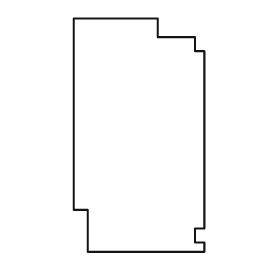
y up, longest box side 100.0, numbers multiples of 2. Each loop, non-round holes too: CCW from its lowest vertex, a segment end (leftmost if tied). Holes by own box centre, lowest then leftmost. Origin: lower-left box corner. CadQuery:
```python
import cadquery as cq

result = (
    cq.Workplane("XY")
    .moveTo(6.0, 0.0)
    .lineTo(56.0, 0.0)
    .lineTo(56.0, 4.0)
    .lineTo(52.0, 4.0)
    .lineTo(52.0, 10.0)
    .lineTo(56.0, 10.0)
    .lineTo(56.0, 86.0)
    .lineTo(52.0, 86.0)
    .lineTo(52.0, 92.0)
    .lineTo(36.0, 92.0)
    .lineTo(36.0, 100.0)
    .lineTo(0.0, 100.0)
    .lineTo(0.0, 18.0)
    .lineTo(6.0, 18.0)
    .close()
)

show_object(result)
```